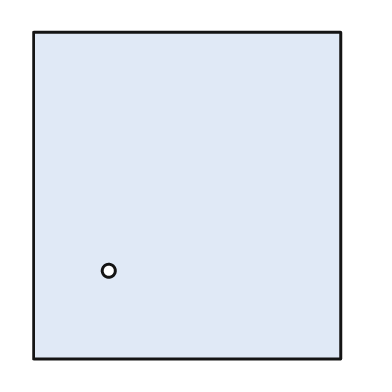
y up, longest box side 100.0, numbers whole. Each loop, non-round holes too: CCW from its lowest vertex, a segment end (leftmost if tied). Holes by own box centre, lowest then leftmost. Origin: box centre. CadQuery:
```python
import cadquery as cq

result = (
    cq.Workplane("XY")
    .moveTo(-47.0, -50.0)
    .lineTo(47.0, -50.0)
    .lineTo(47.0, 50.0)
    .lineTo(-47.0, 50.0)
    .close()
    .moveTo(-24.0, -23.0)
    .circle(2.0)
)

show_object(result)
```